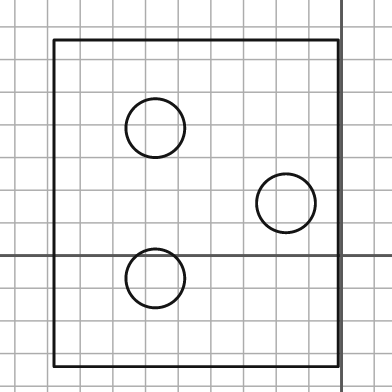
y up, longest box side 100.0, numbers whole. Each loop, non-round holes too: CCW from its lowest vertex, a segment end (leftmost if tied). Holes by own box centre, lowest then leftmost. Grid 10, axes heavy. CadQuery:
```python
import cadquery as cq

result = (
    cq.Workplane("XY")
    .moveTo(-88.0, -34.0)
    .lineTo(-1.0, -34.0)
    .lineTo(-1.0, 66.0)
    .lineTo(-88.0, 66.0)
    .close()
    .moveTo(-57.0, -7.0)
    .circle(9.0)
    .moveTo(-17.0, 16.0)
    .circle(9.0)
    .moveTo(-57.0, 39.0)
    .circle(9.0)
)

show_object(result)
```